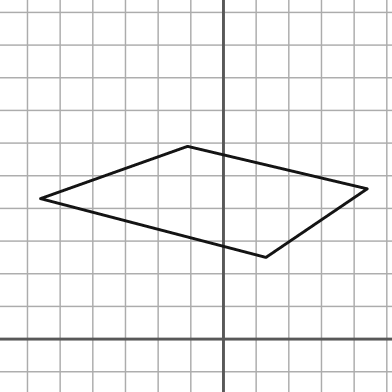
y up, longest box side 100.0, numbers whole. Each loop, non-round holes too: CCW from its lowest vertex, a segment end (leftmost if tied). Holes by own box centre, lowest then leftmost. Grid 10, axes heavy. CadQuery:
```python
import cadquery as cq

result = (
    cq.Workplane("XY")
    .moveTo(13.0, 25.0)
    .lineTo(44.0, 46.0)
    .lineTo(-11.0, 59.0)
    .lineTo(-56.0, 43.0)
    .close()
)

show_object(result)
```